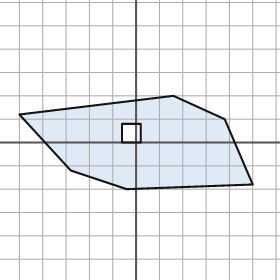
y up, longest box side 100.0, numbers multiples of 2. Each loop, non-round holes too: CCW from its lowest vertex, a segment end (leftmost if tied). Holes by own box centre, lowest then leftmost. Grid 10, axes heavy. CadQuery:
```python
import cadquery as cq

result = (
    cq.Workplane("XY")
    .moveTo(-4.0, -20.0)
    .lineTo(50.0, -18.0)
    .lineTo(38.0, 10.0)
    .lineTo(16.0, 20.0)
    .lineTo(-50.0, 12.0)
    .lineTo(-28.0, -12.0)
    .close()
    .moveTo(-6.0, 0.0)
    .lineTo(2.0, 0.0)
    .lineTo(2.0, 8.0)
    .lineTo(-6.0, 8.0)
    .close()
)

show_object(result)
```